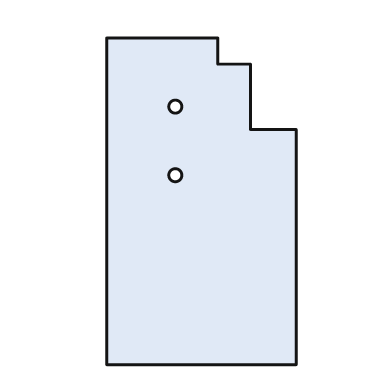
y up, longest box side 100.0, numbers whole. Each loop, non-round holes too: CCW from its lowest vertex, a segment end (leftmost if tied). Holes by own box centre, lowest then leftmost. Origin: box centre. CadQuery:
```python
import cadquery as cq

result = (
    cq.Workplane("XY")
    .moveTo(-29.0, -50.0)
    .lineTo(29.0, -50.0)
    .lineTo(29.0, 22.0)
    .lineTo(15.0, 22.0)
    .lineTo(15.0, 42.0)
    .lineTo(5.0, 42.0)
    .lineTo(5.0, 50.0)
    .lineTo(-29.0, 50.0)
    .close()
    .moveTo(-8.0, 8.0)
    .circle(2.0)
    .moveTo(-8.0, 29.0)
    .circle(2.0)
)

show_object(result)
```